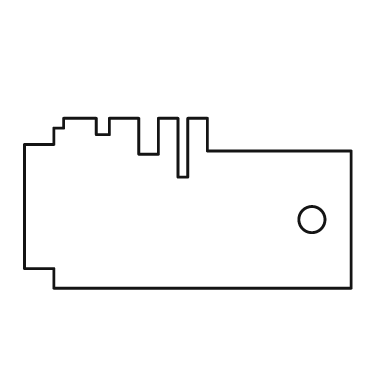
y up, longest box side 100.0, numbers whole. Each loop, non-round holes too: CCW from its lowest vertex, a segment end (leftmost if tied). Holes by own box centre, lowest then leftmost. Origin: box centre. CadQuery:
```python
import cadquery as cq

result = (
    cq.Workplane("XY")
    .moveTo(-41.0, -26.0)
    .lineTo(50.0, -26.0)
    .lineTo(50.0, 16.0)
    .lineTo(6.0, 16.0)
    .lineTo(6.0, 26.0)
    .lineTo(0.0, 26.0)
    .lineTo(0.0, 8.0)
    .lineTo(-3.0, 8.0)
    .lineTo(-3.0, 26.0)
    .lineTo(-9.0, 26.0)
    .lineTo(-9.0, 15.0)
    .lineTo(-15.0, 15.0)
    .lineTo(-15.0, 26.0)
    .lineTo(-24.0, 26.0)
    .lineTo(-24.0, 21.0)
    .lineTo(-28.0, 21.0)
    .lineTo(-28.0, 26.0)
    .lineTo(-38.0, 26.0)
    .lineTo(-38.0, 23.0)
    .lineTo(-41.0, 23.0)
    .lineTo(-41.0, 18.0)
    .lineTo(-50.0, 18.0)
    .lineTo(-50.0, -20.0)
    .lineTo(-41.0, -20.0)
    .close()
    .moveTo(38.0, -5.0)
    .circle(4.0)
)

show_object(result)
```